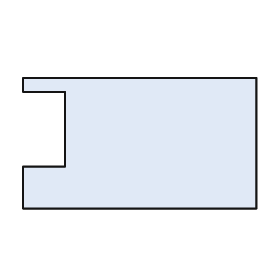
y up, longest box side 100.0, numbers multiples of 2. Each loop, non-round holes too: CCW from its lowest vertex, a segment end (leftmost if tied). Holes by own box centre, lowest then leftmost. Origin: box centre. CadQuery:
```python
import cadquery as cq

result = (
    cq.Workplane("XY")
    .moveTo(-50.0, -28.0)
    .lineTo(50.0, -28.0)
    .lineTo(50.0, 28.0)
    .lineTo(-50.0, 28.0)
    .lineTo(-50.0, 22.0)
    .lineTo(-32.0, 22.0)
    .lineTo(-32.0, -10.0)
    .lineTo(-50.0, -10.0)
    .close()
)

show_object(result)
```